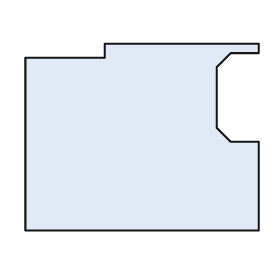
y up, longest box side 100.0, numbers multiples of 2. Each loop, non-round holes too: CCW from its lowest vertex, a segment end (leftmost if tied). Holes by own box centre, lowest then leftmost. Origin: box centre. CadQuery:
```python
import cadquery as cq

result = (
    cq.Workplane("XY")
    .moveTo(-50.0, -40.0)
    .lineTo(50.0, -40.0)
    .lineTo(50.0, -2.0)
    .lineTo(38.0, -2.0)
    .lineTo(32.0, 4.0)
    .lineTo(32.0, 30.0)
    .lineTo(38.0, 36.0)
    .lineTo(50.0, 36.0)
    .lineTo(50.0, 40.0)
    .lineTo(-16.0, 40.0)
    .lineTo(-16.0, 34.0)
    .lineTo(-50.0, 34.0)
    .close()
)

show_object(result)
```